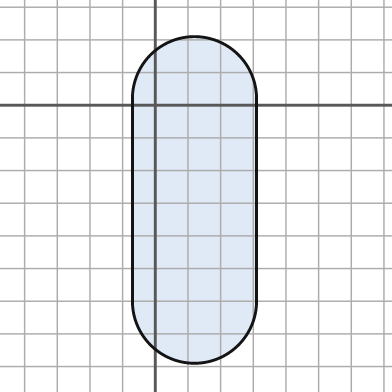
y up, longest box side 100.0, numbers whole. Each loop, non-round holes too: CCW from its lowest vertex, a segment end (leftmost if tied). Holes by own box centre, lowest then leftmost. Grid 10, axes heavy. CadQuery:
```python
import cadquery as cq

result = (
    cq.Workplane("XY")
    .moveTo(-7.0, -60.0)
    .threePointArc((12.0, -79.0), (31.0, -60.0))
    .lineTo(31.0, 2.0)
    .threePointArc((12.0, 21.0), (-7.0, 2.0))
    .close()
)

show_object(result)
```